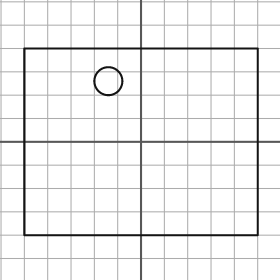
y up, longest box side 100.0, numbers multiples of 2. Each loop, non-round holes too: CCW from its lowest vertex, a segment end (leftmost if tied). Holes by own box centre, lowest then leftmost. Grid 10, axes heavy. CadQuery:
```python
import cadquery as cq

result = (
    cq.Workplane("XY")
    .moveTo(-50.0, -40.0)
    .lineTo(50.0, -40.0)
    .lineTo(50.0, 40.0)
    .lineTo(-50.0, 40.0)
    .close()
    .moveTo(-14.0, 26.0)
    .circle(6.0)
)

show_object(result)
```